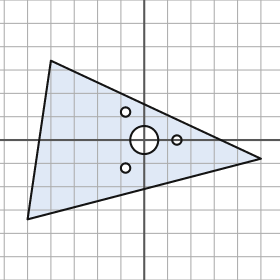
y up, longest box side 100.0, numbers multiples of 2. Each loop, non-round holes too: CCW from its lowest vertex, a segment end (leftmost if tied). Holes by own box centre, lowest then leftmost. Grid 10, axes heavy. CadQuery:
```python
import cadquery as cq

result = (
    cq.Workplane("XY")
    .moveTo(-50.0, -34.0)
    .lineTo(50.0, -8.0)
    .lineTo(-40.0, 34.0)
    .close()
    .moveTo(-8.0, -12.0)
    .circle(2.0)
    .moveTo(0.0, 0.0)
    .circle(6.0)
    .moveTo(14.0, 0.0)
    .circle(2.0)
    .moveTo(-8.0, 12.0)
    .circle(2.0)
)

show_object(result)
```